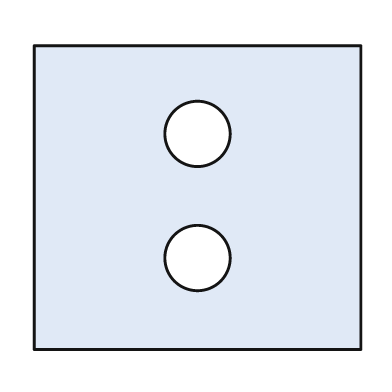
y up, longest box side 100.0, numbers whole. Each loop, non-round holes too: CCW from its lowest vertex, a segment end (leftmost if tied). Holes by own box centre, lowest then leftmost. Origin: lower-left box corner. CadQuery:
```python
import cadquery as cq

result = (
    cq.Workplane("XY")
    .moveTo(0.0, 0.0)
    .lineTo(100.0, 0.0)
    .lineTo(100.0, 93.0)
    .lineTo(0.0, 93.0)
    .close()
    .moveTo(50.0, 28.0)
    .circle(10.0)
    .moveTo(50.0, 66.0)
    .circle(10.0)
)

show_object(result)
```